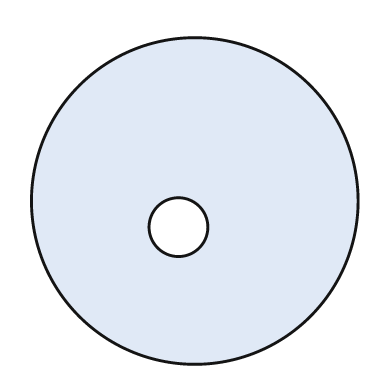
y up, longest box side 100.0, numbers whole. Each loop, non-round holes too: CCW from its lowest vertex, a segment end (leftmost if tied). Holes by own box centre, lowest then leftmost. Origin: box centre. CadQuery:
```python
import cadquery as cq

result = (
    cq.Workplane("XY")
    .moveTo(0.0, 0.0)
    .circle(50.0)
    .moveTo(-5.0, -8.0)
    .circle(9.0)
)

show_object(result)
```